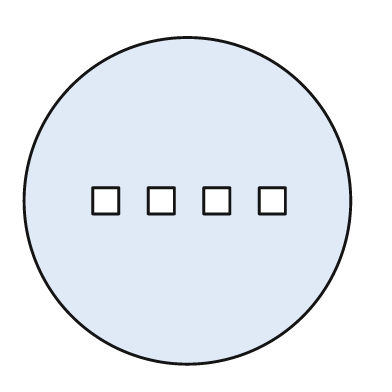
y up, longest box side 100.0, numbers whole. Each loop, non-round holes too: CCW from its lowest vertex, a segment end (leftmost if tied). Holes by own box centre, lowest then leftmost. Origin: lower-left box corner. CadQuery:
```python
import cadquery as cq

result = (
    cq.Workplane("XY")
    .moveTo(50.0, 50.0)
    .circle(50.0)
    .moveTo(21.0, 46.0)
    .lineTo(29.0, 46.0)
    .lineTo(29.0, 54.0)
    .lineTo(21.0, 54.0)
    .close()
    .moveTo(38.0, 46.0)
    .lineTo(46.0, 46.0)
    .lineTo(46.0, 54.0)
    .lineTo(38.0, 54.0)
    .close()
    .moveTo(55.0, 46.0)
    .lineTo(63.0, 46.0)
    .lineTo(63.0, 54.0)
    .lineTo(55.0, 54.0)
    .close()
    .moveTo(72.0, 46.0)
    .lineTo(80.0, 46.0)
    .lineTo(80.0, 54.0)
    .lineTo(72.0, 54.0)
    .close()
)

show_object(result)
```